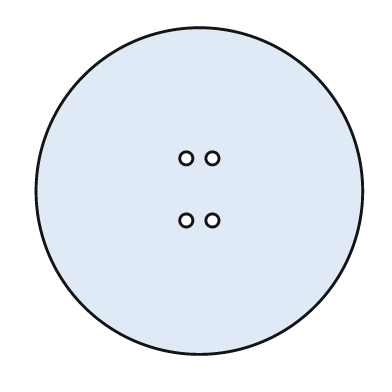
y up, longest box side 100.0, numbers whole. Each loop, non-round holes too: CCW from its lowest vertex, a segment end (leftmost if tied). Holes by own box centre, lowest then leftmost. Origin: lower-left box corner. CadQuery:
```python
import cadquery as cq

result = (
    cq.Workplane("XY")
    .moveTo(50.0, 50.0)
    .circle(50.0)
    .moveTo(46.0, 41.0)
    .circle(2.0)
    .moveTo(54.0, 41.0)
    .circle(2.0)
    .moveTo(46.0, 60.0)
    .circle(2.0)
    .moveTo(54.0, 60.0)
    .circle(2.0)
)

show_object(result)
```